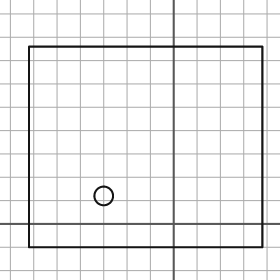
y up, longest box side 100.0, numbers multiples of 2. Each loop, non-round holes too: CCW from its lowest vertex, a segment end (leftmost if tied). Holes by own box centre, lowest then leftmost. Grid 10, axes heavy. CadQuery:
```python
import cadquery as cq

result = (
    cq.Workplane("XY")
    .moveTo(-62.0, -10.0)
    .lineTo(38.0, -10.0)
    .lineTo(38.0, 76.0)
    .lineTo(-62.0, 76.0)
    .close()
    .moveTo(-30.0, 12.0)
    .circle(4.0)
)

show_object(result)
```